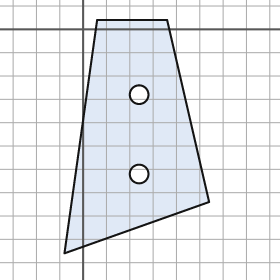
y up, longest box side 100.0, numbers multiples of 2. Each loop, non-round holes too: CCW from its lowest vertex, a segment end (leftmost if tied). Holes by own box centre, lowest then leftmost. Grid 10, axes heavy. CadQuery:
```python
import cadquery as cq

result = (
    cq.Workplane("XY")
    .moveTo(-8.0, -96.0)
    .lineTo(54.0, -74.0)
    .lineTo(36.0, 4.0)
    .lineTo(6.0, 4.0)
    .close()
    .moveTo(24.0, -62.0)
    .circle(4.0)
    .moveTo(24.0, -28.0)
    .circle(4.0)
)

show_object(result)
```